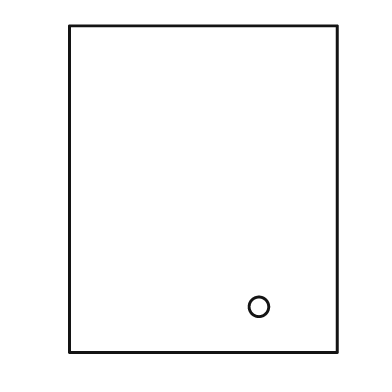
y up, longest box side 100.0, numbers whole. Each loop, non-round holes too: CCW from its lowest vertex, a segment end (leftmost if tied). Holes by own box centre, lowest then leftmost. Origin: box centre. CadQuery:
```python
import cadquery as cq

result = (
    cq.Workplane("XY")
    .moveTo(-41.0, -50.0)
    .lineTo(41.0, -50.0)
    .lineTo(41.0, 50.0)
    .lineTo(-41.0, 50.0)
    .close()
    .moveTo(17.0, -36.0)
    .circle(3.0)
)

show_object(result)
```